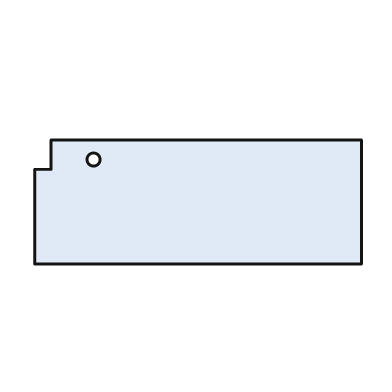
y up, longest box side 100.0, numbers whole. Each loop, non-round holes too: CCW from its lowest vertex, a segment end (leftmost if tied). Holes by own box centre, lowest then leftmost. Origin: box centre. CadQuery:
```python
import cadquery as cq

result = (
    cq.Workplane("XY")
    .moveTo(-50.0, -19.0)
    .lineTo(50.0, -19.0)
    .lineTo(50.0, 19.0)
    .lineTo(-45.0, 19.0)
    .lineTo(-45.0, 10.0)
    .lineTo(-50.0, 10.0)
    .close()
    .moveTo(-32.0, 13.0)
    .circle(2.0)
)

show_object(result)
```